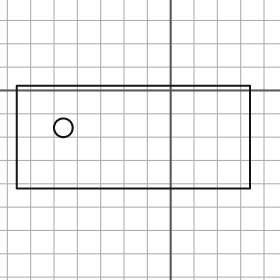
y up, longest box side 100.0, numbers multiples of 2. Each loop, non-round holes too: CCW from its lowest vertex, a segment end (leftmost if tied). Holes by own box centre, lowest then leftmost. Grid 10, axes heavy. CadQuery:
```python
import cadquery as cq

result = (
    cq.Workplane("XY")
    .moveTo(-66.0, -42.0)
    .lineTo(34.0, -42.0)
    .lineTo(34.0, 2.0)
    .lineTo(-66.0, 2.0)
    .close()
    .moveTo(-46.0, -16.0)
    .circle(4.0)
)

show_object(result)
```